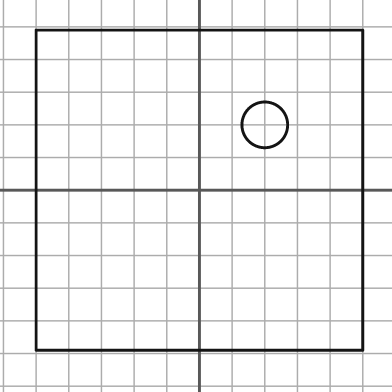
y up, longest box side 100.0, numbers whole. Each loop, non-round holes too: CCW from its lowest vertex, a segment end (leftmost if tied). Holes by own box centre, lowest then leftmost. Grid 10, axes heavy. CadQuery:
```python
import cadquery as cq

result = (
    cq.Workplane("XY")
    .moveTo(-50.0, -49.0)
    .lineTo(50.0, -49.0)
    .lineTo(50.0, 49.0)
    .lineTo(-50.0, 49.0)
    .close()
    .moveTo(20.0, 20.0)
    .circle(7.0)
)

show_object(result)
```